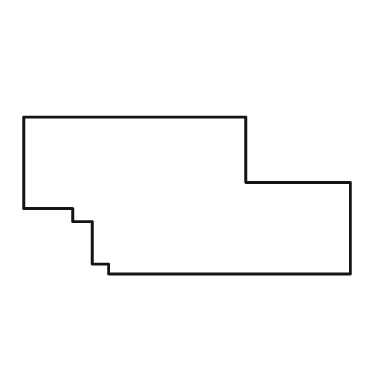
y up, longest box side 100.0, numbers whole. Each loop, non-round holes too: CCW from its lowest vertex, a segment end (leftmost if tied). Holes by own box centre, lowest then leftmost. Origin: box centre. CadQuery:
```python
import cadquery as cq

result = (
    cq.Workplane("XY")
    .moveTo(-24.0, -24.0)
    .lineTo(50.0, -24.0)
    .lineTo(50.0, 4.0)
    .lineTo(18.0, 4.0)
    .lineTo(18.0, 24.0)
    .lineTo(-50.0, 24.0)
    .lineTo(-50.0, -4.0)
    .lineTo(-35.0, -4.0)
    .lineTo(-35.0, -8.0)
    .lineTo(-29.0, -8.0)
    .lineTo(-29.0, -21.0)
    .lineTo(-24.0, -21.0)
    .close()
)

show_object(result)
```